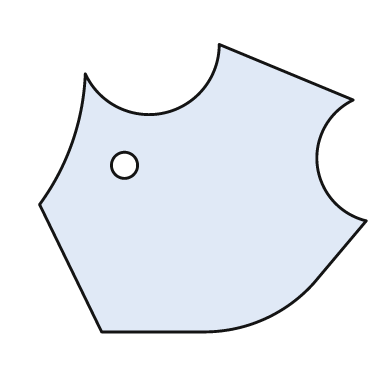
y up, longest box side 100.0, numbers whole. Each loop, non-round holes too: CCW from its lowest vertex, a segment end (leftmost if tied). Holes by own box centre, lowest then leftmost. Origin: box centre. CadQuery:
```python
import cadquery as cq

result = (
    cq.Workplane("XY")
    .moveTo(-31.0, -44.0)
    .lineTo(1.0, -44.0)
    .threePointArc((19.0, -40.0), (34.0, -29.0))
    .lineTo(50.0, -10.0)
    .threePointArc((35.0, 7.0), (46.0, 27.0))
    .lineTo(5.0, 44.0)
    .threePointArc((-12.0, 23.0), (-36.0, 35.0))
    .threePointArc((-40.0, 14.0), (-50.0, -5.0))
    .close()
    .moveTo(-24.0, 7.0)
    .circle(4.0)
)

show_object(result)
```